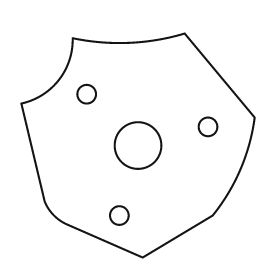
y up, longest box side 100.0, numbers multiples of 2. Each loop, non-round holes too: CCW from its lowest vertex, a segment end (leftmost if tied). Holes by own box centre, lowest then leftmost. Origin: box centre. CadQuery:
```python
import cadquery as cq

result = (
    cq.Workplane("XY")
    .moveTo(2.0, -48.0)
    .lineTo(32.0, -30.0)
    .threePointArc((44.0, -10.0), (50.0, 12.0))
    .lineTo(20.0, 48.0)
    .threePointArc((-4.0, 44.0), (-28.0, 46.0))
    .threePointArc((-34.0, 28.0), (-50.0, 18.0))
    .lineTo(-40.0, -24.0)
    .threePointArc((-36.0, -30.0), (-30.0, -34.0))
    .close()
    .moveTo(-8.0, -30.0)
    .circle(4.0)
    .moveTo(0.0, 0.0)
    .circle(10.0)
    .moveTo(30.0, 8.0)
    .circle(4.0)
    .moveTo(-22.0, 22.0)
    .circle(4.0)
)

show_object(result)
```